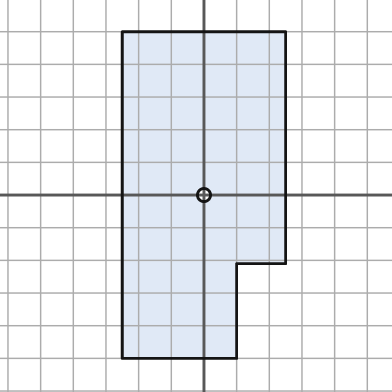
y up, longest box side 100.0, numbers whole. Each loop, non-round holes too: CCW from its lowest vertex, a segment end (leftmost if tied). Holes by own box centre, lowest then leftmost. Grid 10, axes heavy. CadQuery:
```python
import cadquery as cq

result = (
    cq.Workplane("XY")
    .moveTo(-25.0, -50.0)
    .lineTo(10.0, -50.0)
    .lineTo(10.0, -21.0)
    .lineTo(25.0, -21.0)
    .lineTo(25.0, 50.0)
    .lineTo(-25.0, 50.0)
    .close()
    .moveTo(0.0, 0.0)
    .circle(2.0)
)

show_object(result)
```